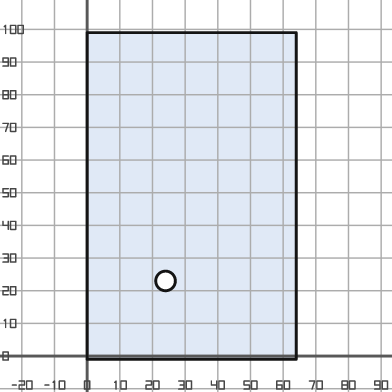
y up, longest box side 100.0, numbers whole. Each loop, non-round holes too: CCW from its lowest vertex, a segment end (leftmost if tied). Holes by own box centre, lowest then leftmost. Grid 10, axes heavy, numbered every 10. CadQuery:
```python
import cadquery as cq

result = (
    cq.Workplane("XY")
    .moveTo(0.0, -1.0)
    .lineTo(64.0, -1.0)
    .lineTo(64.0, 99.0)
    .lineTo(0.0, 99.0)
    .close()
    .moveTo(24.0, 23.0)
    .circle(3.0)
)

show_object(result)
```